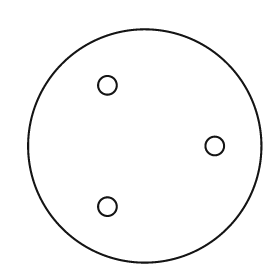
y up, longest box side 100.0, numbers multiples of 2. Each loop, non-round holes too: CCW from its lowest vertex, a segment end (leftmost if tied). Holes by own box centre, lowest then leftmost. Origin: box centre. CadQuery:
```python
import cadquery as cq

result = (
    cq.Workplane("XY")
    .moveTo(0.0, 0.0)
    .circle(50.0)
    .moveTo(-16.0, -26.0)
    .circle(4.0)
    .moveTo(30.0, 0.0)
    .circle(4.0)
    .moveTo(-16.0, 26.0)
    .circle(4.0)
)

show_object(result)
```